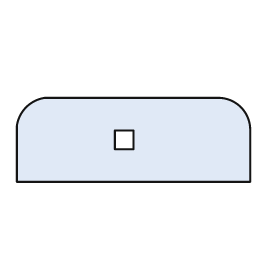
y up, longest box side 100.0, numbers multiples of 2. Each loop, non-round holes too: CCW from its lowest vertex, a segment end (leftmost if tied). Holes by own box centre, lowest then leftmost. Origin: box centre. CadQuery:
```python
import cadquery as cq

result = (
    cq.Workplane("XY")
    .moveTo(-50.0, -18.0)
    .lineTo(50.0, -18.0)
    .lineTo(50.0, 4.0)
    .threePointArc((46.0, 14.0), (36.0, 18.0))
    .lineTo(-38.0, 18.0)
    .threePointArc((-46.0, 14.0), (-50.0, 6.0))
    .close()
    .moveTo(-8.0, -4.0)
    .lineTo(0.0, -4.0)
    .lineTo(0.0, 4.0)
    .lineTo(-8.0, 4.0)
    .close()
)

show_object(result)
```